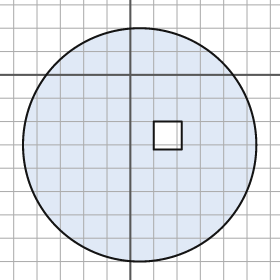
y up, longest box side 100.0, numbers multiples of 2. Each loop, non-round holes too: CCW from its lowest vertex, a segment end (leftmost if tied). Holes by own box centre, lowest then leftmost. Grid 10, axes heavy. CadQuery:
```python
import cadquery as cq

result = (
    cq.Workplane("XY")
    .moveTo(4.0, -30.0)
    .circle(50.0)
    .moveTo(10.0, -32.0)
    .lineTo(22.0, -32.0)
    .lineTo(22.0, -20.0)
    .lineTo(10.0, -20.0)
    .close()
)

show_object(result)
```